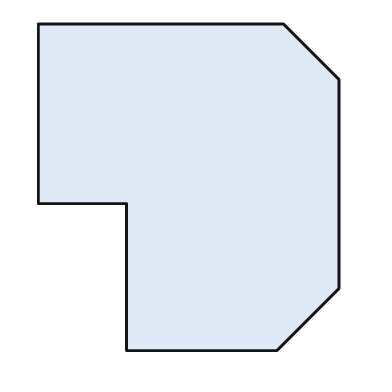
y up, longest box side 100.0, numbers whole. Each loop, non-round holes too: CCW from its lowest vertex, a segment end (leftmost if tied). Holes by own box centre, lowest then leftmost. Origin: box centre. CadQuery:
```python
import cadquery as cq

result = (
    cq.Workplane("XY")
    .moveTo(-19.0, -50.0)
    .lineTo(27.0, -50.0)
    .lineTo(46.0, -31.0)
    .lineTo(46.0, 33.0)
    .lineTo(29.0, 50.0)
    .lineTo(-46.0, 50.0)
    .lineTo(-46.0, -5.0)
    .lineTo(-19.0, -5.0)
    .close()
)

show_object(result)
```